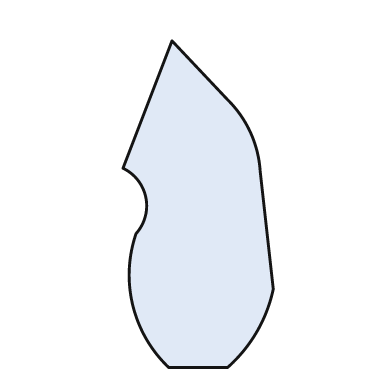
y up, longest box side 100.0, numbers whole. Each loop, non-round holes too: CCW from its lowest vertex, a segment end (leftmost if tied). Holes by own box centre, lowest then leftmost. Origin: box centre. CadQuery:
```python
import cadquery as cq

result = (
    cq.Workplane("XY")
    .moveTo(-9.0, -50.0)
    .lineTo(9.0, -50.0)
    .threePointArc((18.0, -39.0), (23.0, -26.0))
    .lineTo(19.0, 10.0)
    .threePointArc((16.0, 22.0), (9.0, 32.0))
    .lineTo(-8.0, 50.0)
    .lineTo(-23.0, 11.0)
    .threePointArc((-16.0, 2.0), (-19.0, -9.0))
    .threePointArc((-20.0, -31.0), (-9.0, -50.0))
    .close()
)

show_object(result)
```